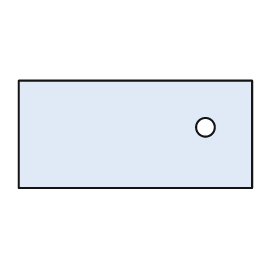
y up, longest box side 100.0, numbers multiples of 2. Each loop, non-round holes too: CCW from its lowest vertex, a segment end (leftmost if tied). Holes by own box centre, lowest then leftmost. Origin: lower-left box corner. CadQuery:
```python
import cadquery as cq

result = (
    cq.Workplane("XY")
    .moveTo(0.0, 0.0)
    .lineTo(100.0, 0.0)
    .lineTo(100.0, 46.0)
    .lineTo(0.0, 46.0)
    .close()
    .moveTo(80.0, 26.0)
    .circle(4.0)
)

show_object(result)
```